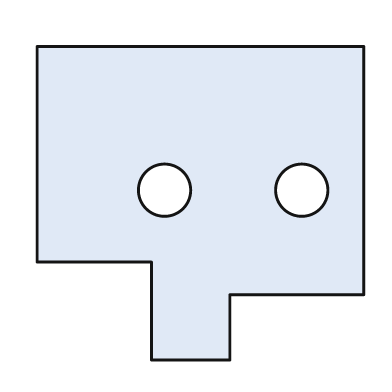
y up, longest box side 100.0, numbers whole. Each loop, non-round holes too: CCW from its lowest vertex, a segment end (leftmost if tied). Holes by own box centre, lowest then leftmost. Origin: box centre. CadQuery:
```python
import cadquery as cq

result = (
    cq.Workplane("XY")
    .moveTo(-15.0, -48.0)
    .lineTo(9.0, -48.0)
    .lineTo(9.0, -28.0)
    .lineTo(50.0, -28.0)
    .lineTo(50.0, 48.0)
    .lineTo(-50.0, 48.0)
    .lineTo(-50.0, -18.0)
    .lineTo(-15.0, -18.0)
    .close()
    .moveTo(-11.0, 4.0)
    .circle(8.0)
    .moveTo(31.0, 4.0)
    .circle(8.0)
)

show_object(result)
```